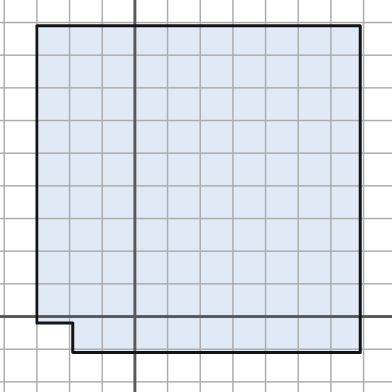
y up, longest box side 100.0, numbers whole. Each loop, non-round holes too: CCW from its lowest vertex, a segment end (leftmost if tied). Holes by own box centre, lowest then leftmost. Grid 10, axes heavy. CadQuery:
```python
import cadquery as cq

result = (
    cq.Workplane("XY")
    .moveTo(-19.0, -11.0)
    .lineTo(69.0, -11.0)
    .lineTo(69.0, 89.0)
    .lineTo(-30.0, 89.0)
    .lineTo(-30.0, -2.0)
    .lineTo(-19.0, -2.0)
    .close()
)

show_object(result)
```